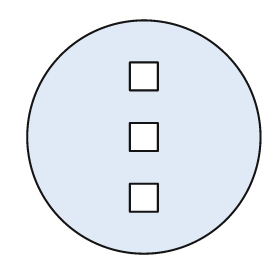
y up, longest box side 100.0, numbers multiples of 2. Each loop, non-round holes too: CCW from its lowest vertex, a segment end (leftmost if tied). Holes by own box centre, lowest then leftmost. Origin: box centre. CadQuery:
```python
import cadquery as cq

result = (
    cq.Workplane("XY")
    .moveTo(0.0, 0.0)
    .circle(50.0)
    .moveTo(-6.0, -32.0)
    .lineTo(6.0, -32.0)
    .lineTo(6.0, -20.0)
    .lineTo(-6.0, -20.0)
    .close()
    .moveTo(-6.0, -6.0)
    .lineTo(6.0, -6.0)
    .lineTo(6.0, 6.0)
    .lineTo(-6.0, 6.0)
    .close()
    .moveTo(-6.0, 20.0)
    .lineTo(6.0, 20.0)
    .lineTo(6.0, 32.0)
    .lineTo(-6.0, 32.0)
    .close()
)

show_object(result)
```